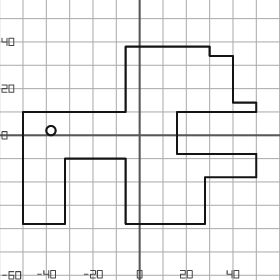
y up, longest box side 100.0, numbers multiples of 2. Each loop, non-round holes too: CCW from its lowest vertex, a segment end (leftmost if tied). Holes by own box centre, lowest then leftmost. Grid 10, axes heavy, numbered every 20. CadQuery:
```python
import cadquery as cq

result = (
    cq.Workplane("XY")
    .moveTo(-50.0, -38.0)
    .lineTo(-32.0, -38.0)
    .lineTo(-32.0, -10.0)
    .lineTo(-6.0, -10.0)
    .lineTo(-6.0, -38.0)
    .lineTo(28.0, -38.0)
    .lineTo(28.0, -18.0)
    .lineTo(50.0, -18.0)
    .lineTo(50.0, -8.0)
    .lineTo(16.0, -8.0)
    .lineTo(16.0, 10.0)
    .lineTo(50.0, 10.0)
    .lineTo(50.0, 14.0)
    .lineTo(40.0, 14.0)
    .lineTo(40.0, 34.0)
    .lineTo(30.0, 34.0)
    .lineTo(30.0, 38.0)
    .lineTo(-6.0, 38.0)
    .lineTo(-6.0, 10.0)
    .lineTo(-50.0, 10.0)
    .close()
    .moveTo(-38.0, 2.0)
    .circle(2.0)
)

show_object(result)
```